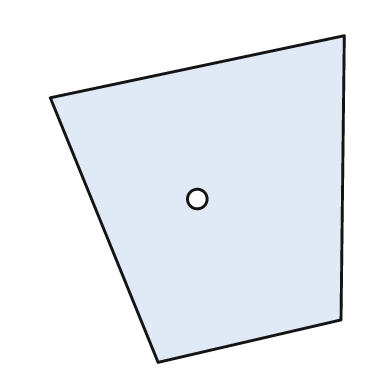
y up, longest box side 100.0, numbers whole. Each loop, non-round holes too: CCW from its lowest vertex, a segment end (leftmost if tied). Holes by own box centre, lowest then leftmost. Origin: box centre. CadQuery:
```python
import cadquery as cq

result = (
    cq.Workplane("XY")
    .moveTo(-12.0, -50.0)
    .lineTo(44.0, -37.0)
    .lineTo(45.0, 50.0)
    .lineTo(-45.0, 31.0)
    .close()
    .moveTo(0.0, 0.0)
    .circle(3.0)
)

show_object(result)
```